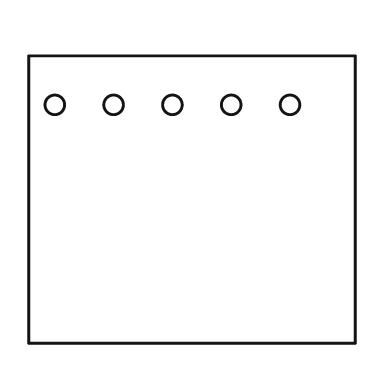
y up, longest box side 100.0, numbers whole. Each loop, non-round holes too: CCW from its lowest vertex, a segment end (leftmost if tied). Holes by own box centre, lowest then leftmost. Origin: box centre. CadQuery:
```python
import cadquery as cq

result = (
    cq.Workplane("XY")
    .moveTo(-50.0, -44.0)
    .lineTo(50.0, -44.0)
    .lineTo(50.0, 44.0)
    .lineTo(-50.0, 44.0)
    .close()
    .moveTo(-42.0, 29.0)
    .circle(3.0)
    .moveTo(-24.0, 29.0)
    .circle(3.0)
    .moveTo(-6.0, 29.0)
    .circle(3.0)
    .moveTo(12.0, 29.0)
    .circle(3.0)
    .moveTo(30.0, 29.0)
    .circle(3.0)
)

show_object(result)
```